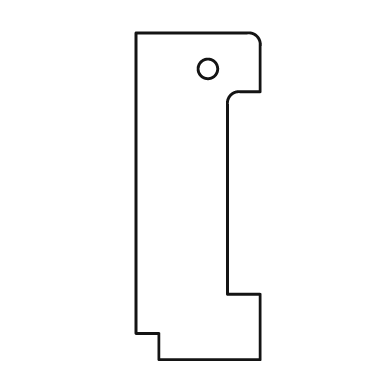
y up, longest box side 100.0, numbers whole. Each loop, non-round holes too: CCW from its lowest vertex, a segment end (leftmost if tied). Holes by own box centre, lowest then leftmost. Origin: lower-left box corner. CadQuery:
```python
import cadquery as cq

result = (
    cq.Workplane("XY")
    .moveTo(7.0, 0.0)
    .lineTo(38.0, 0.0)
    .lineTo(38.0, 20.0)
    .lineTo(28.0, 20.0)
    .lineTo(28.0, 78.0)
    .threePointArc((29.0, 81.0), (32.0, 82.0))
    .lineTo(38.0, 82.0)
    .lineTo(38.0, 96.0)
    .threePointArc((37.0, 99.0), (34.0, 100.0))
    .lineTo(0.0, 100.0)
    .lineTo(0.0, 8.0)
    .lineTo(7.0, 8.0)
    .close()
    .moveTo(22.0, 89.0)
    .circle(3.0)
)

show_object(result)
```